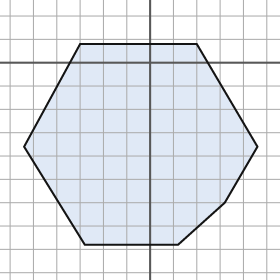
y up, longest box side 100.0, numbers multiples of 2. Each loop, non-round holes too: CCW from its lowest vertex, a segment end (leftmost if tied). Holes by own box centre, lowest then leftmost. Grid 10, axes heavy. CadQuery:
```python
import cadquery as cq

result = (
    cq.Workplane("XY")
    .moveTo(-28.0, -78.0)
    .lineTo(12.0, -78.0)
    .lineTo(32.0, -60.0)
    .lineTo(46.0, -36.0)
    .lineTo(20.0, 8.0)
    .lineTo(-30.0, 8.0)
    .lineTo(-54.0, -36.0)
    .close()
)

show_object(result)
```